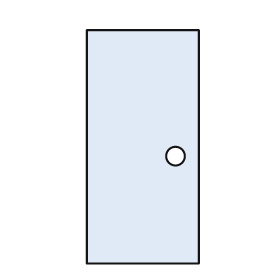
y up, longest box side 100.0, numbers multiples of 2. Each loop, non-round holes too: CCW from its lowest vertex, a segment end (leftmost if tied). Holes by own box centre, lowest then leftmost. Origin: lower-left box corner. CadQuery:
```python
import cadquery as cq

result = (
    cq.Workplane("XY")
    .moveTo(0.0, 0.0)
    .lineTo(48.0, 0.0)
    .lineTo(48.0, 100.0)
    .lineTo(0.0, 100.0)
    .close()
    .moveTo(38.0, 46.0)
    .circle(4.0)
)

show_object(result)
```